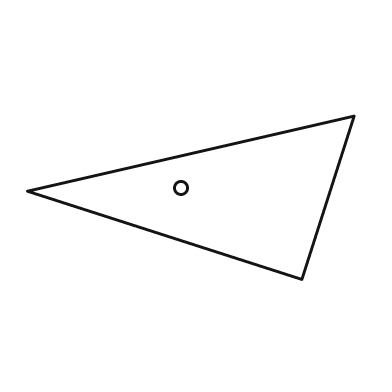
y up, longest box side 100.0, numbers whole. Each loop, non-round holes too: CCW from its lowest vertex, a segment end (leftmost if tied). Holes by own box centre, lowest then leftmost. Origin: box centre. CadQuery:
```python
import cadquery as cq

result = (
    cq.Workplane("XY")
    .moveTo(34.0, -25.0)
    .lineTo(50.0, 25.0)
    .lineTo(-50.0, 2.0)
    .close()
    .moveTo(-3.0, 3.0)
    .circle(2.0)
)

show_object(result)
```